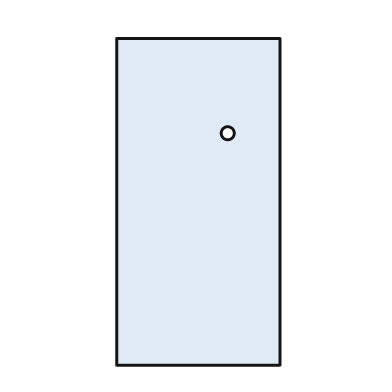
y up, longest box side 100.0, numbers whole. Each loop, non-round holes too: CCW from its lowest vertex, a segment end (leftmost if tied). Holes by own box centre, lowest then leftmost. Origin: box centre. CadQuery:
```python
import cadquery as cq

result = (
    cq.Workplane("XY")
    .moveTo(-25.0, -50.0)
    .lineTo(25.0, -50.0)
    .lineTo(25.0, 50.0)
    .lineTo(-25.0, 50.0)
    .close()
    .moveTo(9.0, 21.0)
    .circle(2.0)
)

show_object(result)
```